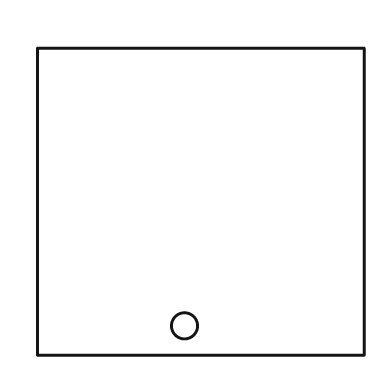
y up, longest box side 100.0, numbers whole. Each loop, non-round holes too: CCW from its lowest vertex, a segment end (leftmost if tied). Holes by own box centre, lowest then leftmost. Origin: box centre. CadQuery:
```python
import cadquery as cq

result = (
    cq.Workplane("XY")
    .moveTo(-50.0, -47.0)
    .lineTo(50.0, -47.0)
    .lineTo(50.0, 47.0)
    .lineTo(-50.0, 47.0)
    .close()
    .moveTo(-5.0, -38.0)
    .circle(4.0)
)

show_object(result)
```